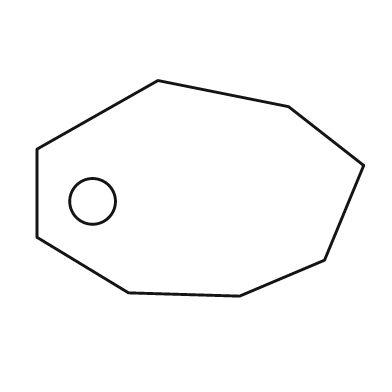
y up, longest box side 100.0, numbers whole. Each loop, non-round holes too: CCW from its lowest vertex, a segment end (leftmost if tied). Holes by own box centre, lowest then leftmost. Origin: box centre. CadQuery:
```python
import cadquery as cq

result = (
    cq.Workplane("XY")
    .moveTo(12.0, -33.0)
    .lineTo(38.0, -22.0)
    .lineTo(50.0, 7.0)
    .lineTo(27.0, 25.0)
    .lineTo(-13.0, 33.0)
    .lineTo(-50.0, 12.0)
    .lineTo(-50.0, -15.0)
    .lineTo(-22.0, -32.0)
    .close()
    .moveTo(-33.0, -4.0)
    .circle(7.0)
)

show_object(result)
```